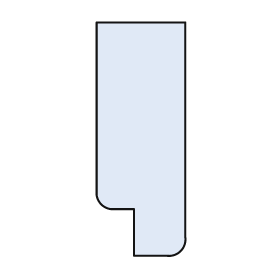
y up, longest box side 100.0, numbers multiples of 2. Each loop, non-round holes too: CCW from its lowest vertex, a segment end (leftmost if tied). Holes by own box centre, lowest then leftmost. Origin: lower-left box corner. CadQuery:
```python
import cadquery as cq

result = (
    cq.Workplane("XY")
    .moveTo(16.0, 0.0)
    .lineTo(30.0, 0.0)
    .threePointArc((36.0, 2.0), (38.0, 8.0))
    .lineTo(38.0, 100.0)
    .lineTo(0.0, 100.0)
    .lineTo(0.0, 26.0)
    .threePointArc((2.0, 22.0), (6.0, 20.0))
    .lineTo(16.0, 20.0)
    .close()
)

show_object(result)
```